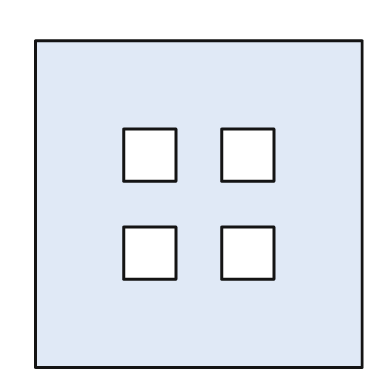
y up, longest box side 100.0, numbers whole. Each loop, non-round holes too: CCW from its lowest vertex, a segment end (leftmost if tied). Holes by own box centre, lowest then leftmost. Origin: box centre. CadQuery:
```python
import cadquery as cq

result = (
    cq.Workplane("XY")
    .moveTo(-50.0, -50.0)
    .lineTo(50.0, -50.0)
    .lineTo(50.0, 50.0)
    .lineTo(-50.0, 50.0)
    .close()
    .moveTo(-23.0, -23.0)
    .lineTo(-7.0, -23.0)
    .lineTo(-7.0, -7.0)
    .lineTo(-23.0, -7.0)
    .close()
    .moveTo(7.0, -23.0)
    .lineTo(23.0, -23.0)
    .lineTo(23.0, -7.0)
    .lineTo(7.0, -7.0)
    .close()
    .moveTo(-23.0, 7.0)
    .lineTo(-7.0, 7.0)
    .lineTo(-7.0, 23.0)
    .lineTo(-23.0, 23.0)
    .close()
    .moveTo(7.0, 7.0)
    .lineTo(23.0, 7.0)
    .lineTo(23.0, 23.0)
    .lineTo(7.0, 23.0)
    .close()
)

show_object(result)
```